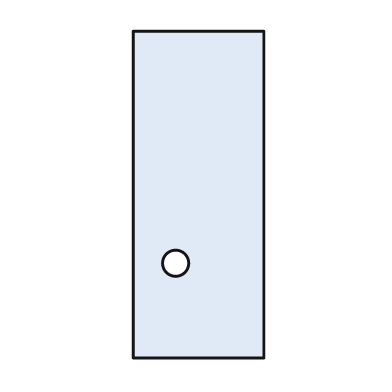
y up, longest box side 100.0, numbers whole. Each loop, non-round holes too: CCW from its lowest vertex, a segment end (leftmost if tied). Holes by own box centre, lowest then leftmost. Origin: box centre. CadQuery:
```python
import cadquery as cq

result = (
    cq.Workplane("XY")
    .moveTo(-20.0, -50.0)
    .lineTo(20.0, -50.0)
    .lineTo(20.0, 50.0)
    .lineTo(-20.0, 50.0)
    .close()
    .moveTo(-7.0, -21.0)
    .circle(4.0)
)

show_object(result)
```